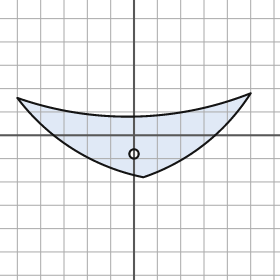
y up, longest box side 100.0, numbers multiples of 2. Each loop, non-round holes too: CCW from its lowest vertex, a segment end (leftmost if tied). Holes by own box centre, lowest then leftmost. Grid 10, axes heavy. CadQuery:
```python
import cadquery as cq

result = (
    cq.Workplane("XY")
    .moveTo(4.0, -18.0)
    .threePointArc((30.0, -4.0), (50.0, 18.0))
    .threePointArc((0.0, 8.0), (-50.0, 16.0))
    .threePointArc((-26.0, -6.0), (4.0, -18.0))
    .close()
    .moveTo(0.0, -8.0)
    .circle(2.0)
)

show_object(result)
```